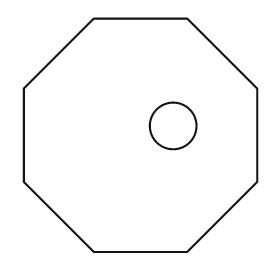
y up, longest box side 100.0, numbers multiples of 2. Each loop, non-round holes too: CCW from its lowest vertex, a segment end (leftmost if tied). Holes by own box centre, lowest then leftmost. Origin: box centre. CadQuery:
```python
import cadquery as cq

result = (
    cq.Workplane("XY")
    .moveTo(-20.0, -50.0)
    .lineTo(20.0, -50.0)
    .lineTo(50.0, -20.0)
    .lineTo(50.0, 20.0)
    .lineTo(20.0, 50.0)
    .lineTo(-20.0, 50.0)
    .lineTo(-50.0, 20.0)
    .lineTo(-50.0, -20.0)
    .close()
    .moveTo(14.0, 4.0)
    .circle(10.0)
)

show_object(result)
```